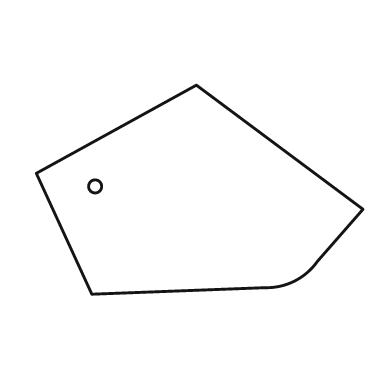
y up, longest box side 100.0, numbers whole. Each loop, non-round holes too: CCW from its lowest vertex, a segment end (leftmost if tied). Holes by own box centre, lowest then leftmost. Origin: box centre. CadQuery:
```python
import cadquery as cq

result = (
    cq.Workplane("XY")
    .moveTo(-33.0, -32.0)
    .lineTo(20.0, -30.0)
    .threePointArc((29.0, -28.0), (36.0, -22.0))
    .lineTo(50.0, -6.0)
    .lineTo(-1.0, 32.0)
    .lineTo(-50.0, 5.0)
    .close()
    .moveTo(-32.0, 1.0)
    .circle(2.0)
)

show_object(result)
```